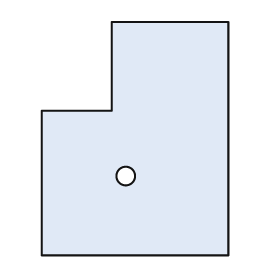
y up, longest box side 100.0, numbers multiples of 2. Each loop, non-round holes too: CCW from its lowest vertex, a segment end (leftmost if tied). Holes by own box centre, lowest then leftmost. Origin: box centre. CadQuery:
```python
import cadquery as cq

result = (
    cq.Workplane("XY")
    .moveTo(-40.0, -50.0)
    .lineTo(40.0, -50.0)
    .lineTo(40.0, 50.0)
    .lineTo(-10.0, 50.0)
    .lineTo(-10.0, 12.0)
    .lineTo(-40.0, 12.0)
    .close()
    .moveTo(-4.0, -16.0)
    .circle(4.0)
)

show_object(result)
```